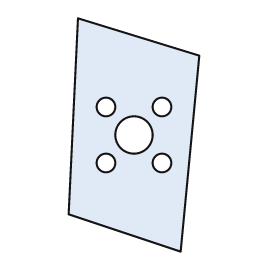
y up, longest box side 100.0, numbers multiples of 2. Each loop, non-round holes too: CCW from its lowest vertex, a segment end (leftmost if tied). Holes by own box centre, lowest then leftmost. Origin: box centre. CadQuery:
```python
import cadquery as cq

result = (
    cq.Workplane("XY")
    .moveTo(20.0, -50.0)
    .lineTo(28.0, 34.0)
    .lineTo(-24.0, 50.0)
    .lineTo(-28.0, -34.0)
    .close()
    .moveTo(-12.0, -12.0)
    .circle(4.0)
    .moveTo(12.0, -12.0)
    .circle(4.0)
    .moveTo(0.0, 0.0)
    .circle(8.0)
    .moveTo(-12.0, 12.0)
    .circle(4.0)
    .moveTo(12.0, 12.0)
    .circle(4.0)
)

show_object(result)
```